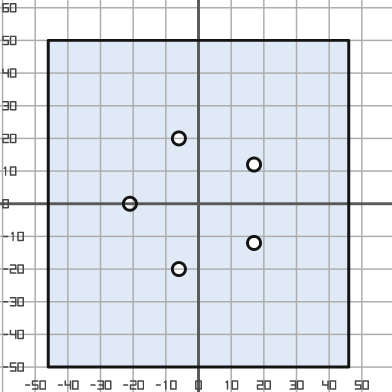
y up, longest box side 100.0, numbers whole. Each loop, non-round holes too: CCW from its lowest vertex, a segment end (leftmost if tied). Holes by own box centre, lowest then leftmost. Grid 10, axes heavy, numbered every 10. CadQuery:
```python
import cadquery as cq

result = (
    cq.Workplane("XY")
    .moveTo(-46.0, -50.0)
    .lineTo(46.0, -50.0)
    .lineTo(46.0, 50.0)
    .lineTo(-46.0, 50.0)
    .close()
    .moveTo(-6.0, -20.0)
    .circle(2.0)
    .moveTo(17.0, -12.0)
    .circle(2.0)
    .moveTo(-21.0, 0.0)
    .circle(2.0)
    .moveTo(17.0, 12.0)
    .circle(2.0)
    .moveTo(-6.0, 20.0)
    .circle(2.0)
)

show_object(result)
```